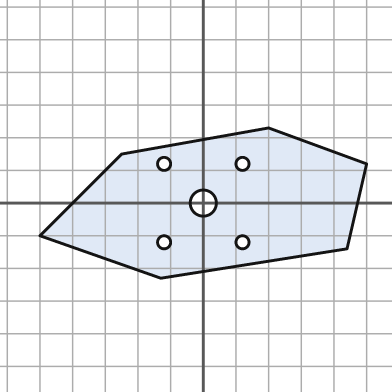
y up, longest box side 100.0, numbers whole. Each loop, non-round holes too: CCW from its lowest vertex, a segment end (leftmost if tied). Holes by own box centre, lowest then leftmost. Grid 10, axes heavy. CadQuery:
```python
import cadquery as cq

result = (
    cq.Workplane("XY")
    .moveTo(-13.0, -23.0)
    .lineTo(44.0, -14.0)
    .lineTo(50.0, 12.0)
    .lineTo(20.0, 23.0)
    .lineTo(-25.0, 15.0)
    .lineTo(-50.0, -10.0)
    .close()
    .moveTo(-12.0, -12.0)
    .circle(2.0)
    .moveTo(12.0, -12.0)
    .circle(2.0)
    .moveTo(0.0, 0.0)
    .circle(4.0)
    .moveTo(-12.0, 12.0)
    .circle(2.0)
    .moveTo(12.0, 12.0)
    .circle(2.0)
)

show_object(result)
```